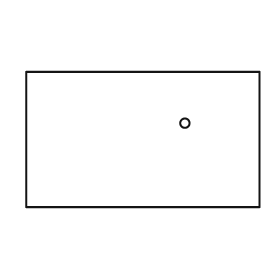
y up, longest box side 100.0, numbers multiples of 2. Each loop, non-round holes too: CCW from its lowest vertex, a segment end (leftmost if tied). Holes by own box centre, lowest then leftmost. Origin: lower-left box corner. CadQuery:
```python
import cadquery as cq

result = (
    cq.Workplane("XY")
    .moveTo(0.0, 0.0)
    .lineTo(100.0, 0.0)
    .lineTo(100.0, 58.0)
    .lineTo(0.0, 58.0)
    .close()
    .moveTo(68.0, 36.0)
    .circle(2.0)
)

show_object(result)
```